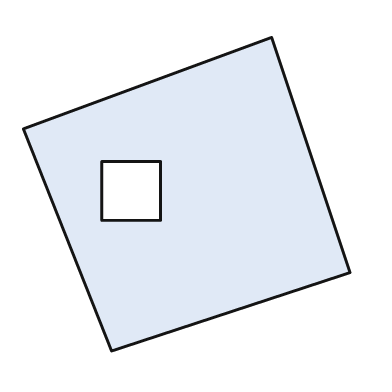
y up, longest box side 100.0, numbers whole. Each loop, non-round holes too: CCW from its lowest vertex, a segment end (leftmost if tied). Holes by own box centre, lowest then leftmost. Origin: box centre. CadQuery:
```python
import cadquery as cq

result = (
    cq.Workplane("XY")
    .moveTo(-23.0, -48.0)
    .lineTo(50.0, -24.0)
    .lineTo(26.0, 48.0)
    .lineTo(-50.0, 20.0)
    .close()
    .moveTo(-26.0, -8.0)
    .lineTo(-8.0, -8.0)
    .lineTo(-8.0, 10.0)
    .lineTo(-26.0, 10.0)
    .close()
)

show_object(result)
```